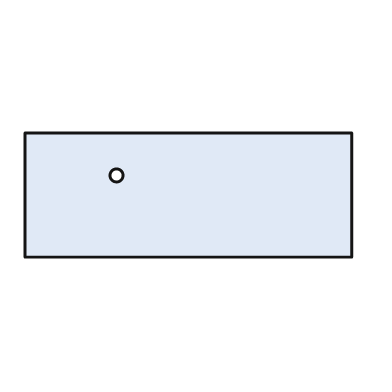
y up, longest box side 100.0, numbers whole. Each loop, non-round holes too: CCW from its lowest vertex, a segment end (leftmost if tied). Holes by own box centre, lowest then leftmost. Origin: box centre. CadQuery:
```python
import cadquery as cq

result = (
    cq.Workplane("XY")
    .moveTo(-50.0, -19.0)
    .lineTo(50.0, -19.0)
    .lineTo(50.0, 19.0)
    .lineTo(-50.0, 19.0)
    .close()
    .moveTo(-22.0, 6.0)
    .circle(2.0)
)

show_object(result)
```